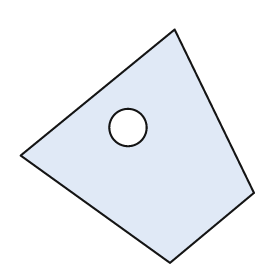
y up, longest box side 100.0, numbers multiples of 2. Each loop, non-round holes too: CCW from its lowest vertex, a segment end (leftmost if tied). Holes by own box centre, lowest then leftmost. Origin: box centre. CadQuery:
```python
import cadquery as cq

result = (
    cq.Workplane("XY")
    .moveTo(14.0, -50.0)
    .lineTo(50.0, -20.0)
    .lineTo(16.0, 50.0)
    .lineTo(-50.0, -4.0)
    .close()
    .moveTo(-4.0, 8.0)
    .circle(8.0)
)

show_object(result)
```